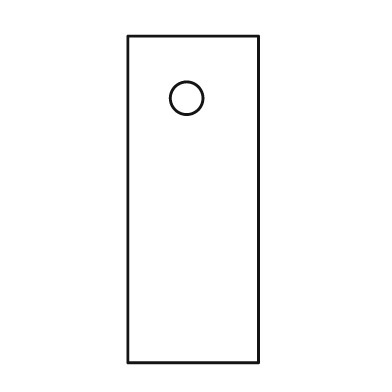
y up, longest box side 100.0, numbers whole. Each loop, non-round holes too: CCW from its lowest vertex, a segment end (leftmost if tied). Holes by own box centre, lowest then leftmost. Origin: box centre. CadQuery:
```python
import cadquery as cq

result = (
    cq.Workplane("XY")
    .moveTo(-20.0, -50.0)
    .lineTo(20.0, -50.0)
    .lineTo(20.0, 50.0)
    .lineTo(-20.0, 50.0)
    .close()
    .moveTo(-2.0, 31.0)
    .circle(5.0)
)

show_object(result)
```